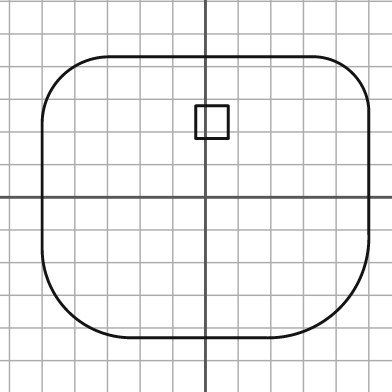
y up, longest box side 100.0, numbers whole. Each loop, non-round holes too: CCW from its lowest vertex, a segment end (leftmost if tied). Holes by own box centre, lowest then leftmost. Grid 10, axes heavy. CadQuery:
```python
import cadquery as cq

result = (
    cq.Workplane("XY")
    .moveTo(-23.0, -43.0)
    .lineTo(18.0, -43.0)
    .threePointArc((41.0, -34.0), (50.0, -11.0))
    .lineTo(50.0, 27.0)
    .threePointArc((45.0, 38.0), (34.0, 43.0))
    .lineTo(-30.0, 43.0)
    .threePointArc((-44.0, 37.0), (-50.0, 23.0))
    .lineTo(-50.0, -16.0)
    .threePointArc((-42.0, -35.0), (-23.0, -43.0))
    .close()
    .moveTo(-3.0, 18.0)
    .lineTo(7.0, 18.0)
    .lineTo(7.0, 28.0)
    .lineTo(-3.0, 28.0)
    .close()
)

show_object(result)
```